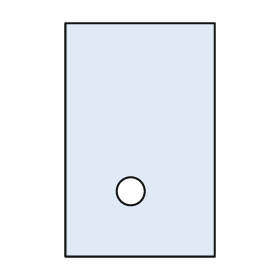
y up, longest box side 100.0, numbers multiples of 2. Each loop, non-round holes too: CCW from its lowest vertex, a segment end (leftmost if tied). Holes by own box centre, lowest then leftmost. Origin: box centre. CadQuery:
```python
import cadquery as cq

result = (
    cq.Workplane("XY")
    .moveTo(-32.0, -50.0)
    .lineTo(32.0, -50.0)
    .lineTo(32.0, 50.0)
    .lineTo(-32.0, 50.0)
    .close()
    .moveTo(-4.0, -22.0)
    .circle(6.0)
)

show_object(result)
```